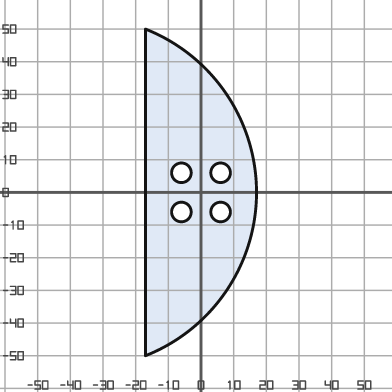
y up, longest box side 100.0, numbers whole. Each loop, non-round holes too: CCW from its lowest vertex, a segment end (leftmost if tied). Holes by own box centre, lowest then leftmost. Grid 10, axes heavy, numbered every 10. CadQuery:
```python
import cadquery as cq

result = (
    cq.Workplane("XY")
    .moveTo(-17.0, -50.0)
    .threePointArc((17.0, 0.0), (-17.0, 50.0))
    .close()
    .moveTo(-6.0, -6.0)
    .circle(3.0)
    .moveTo(6.0, -6.0)
    .circle(3.0)
    .moveTo(-6.0, 6.0)
    .circle(3.0)
    .moveTo(6.0, 6.0)
    .circle(3.0)
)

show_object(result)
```